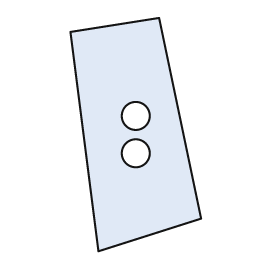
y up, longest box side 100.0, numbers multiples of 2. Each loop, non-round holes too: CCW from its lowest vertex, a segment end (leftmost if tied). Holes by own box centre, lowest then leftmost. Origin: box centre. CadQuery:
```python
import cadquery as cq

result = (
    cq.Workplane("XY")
    .moveTo(-16.0, -50.0)
    .lineTo(28.0, -36.0)
    .lineTo(10.0, 50.0)
    .lineTo(-28.0, 44.0)
    .close()
    .moveTo(0.0, -8.0)
    .circle(6.0)
    .moveTo(0.0, 8.0)
    .circle(6.0)
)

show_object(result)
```